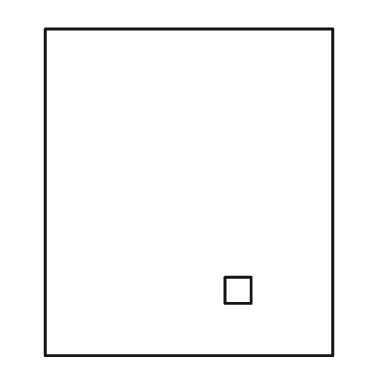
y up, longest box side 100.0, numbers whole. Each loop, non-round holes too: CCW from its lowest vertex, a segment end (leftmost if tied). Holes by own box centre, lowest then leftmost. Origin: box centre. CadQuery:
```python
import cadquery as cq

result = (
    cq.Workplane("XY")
    .moveTo(-44.0, -50.0)
    .lineTo(44.0, -50.0)
    .lineTo(44.0, 50.0)
    .lineTo(-44.0, 50.0)
    .close()
    .moveTo(11.0, -34.0)
    .lineTo(19.0, -34.0)
    .lineTo(19.0, -26.0)
    .lineTo(11.0, -26.0)
    .close()
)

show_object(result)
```